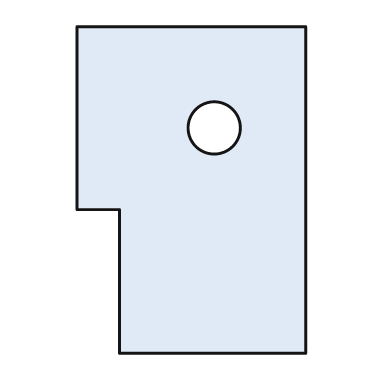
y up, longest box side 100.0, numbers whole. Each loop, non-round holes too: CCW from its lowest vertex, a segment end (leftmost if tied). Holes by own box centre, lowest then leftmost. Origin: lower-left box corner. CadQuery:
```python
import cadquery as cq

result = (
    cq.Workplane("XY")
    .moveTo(13.0, 0.0)
    .lineTo(70.0, 0.0)
    .lineTo(70.0, 100.0)
    .lineTo(0.0, 100.0)
    .lineTo(0.0, 44.0)
    .lineTo(13.0, 44.0)
    .close()
    .moveTo(42.0, 69.0)
    .circle(8.0)
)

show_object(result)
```